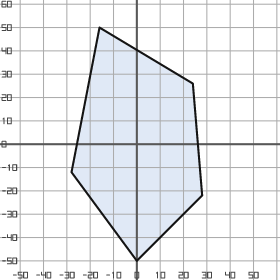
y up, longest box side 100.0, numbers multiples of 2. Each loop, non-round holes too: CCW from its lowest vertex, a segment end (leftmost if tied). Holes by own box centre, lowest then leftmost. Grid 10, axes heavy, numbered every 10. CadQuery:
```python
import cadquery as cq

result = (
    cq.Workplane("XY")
    .moveTo(0.0, -50.0)
    .lineTo(28.0, -22.0)
    .lineTo(24.0, 26.0)
    .lineTo(-16.0, 50.0)
    .lineTo(-28.0, -12.0)
    .close()
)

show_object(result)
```